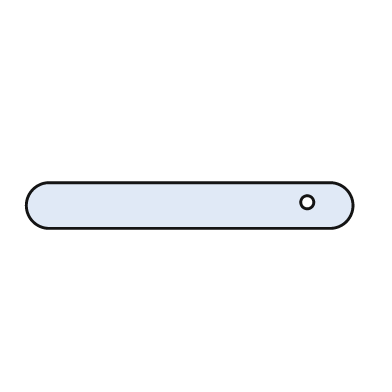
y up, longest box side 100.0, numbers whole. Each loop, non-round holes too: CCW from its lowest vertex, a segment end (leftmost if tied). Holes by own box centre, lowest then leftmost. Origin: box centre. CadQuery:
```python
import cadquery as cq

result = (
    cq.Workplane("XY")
    .moveTo(-43.0, -7.0)
    .lineTo(43.0, -7.0)
    .threePointArc((50.0, 0.0), (43.0, 7.0))
    .lineTo(-43.0, 7.0)
    .threePointArc((-50.0, 0.0), (-43.0, -7.0))
    .close()
    .moveTo(36.0, 1.0)
    .circle(2.0)
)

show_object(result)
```